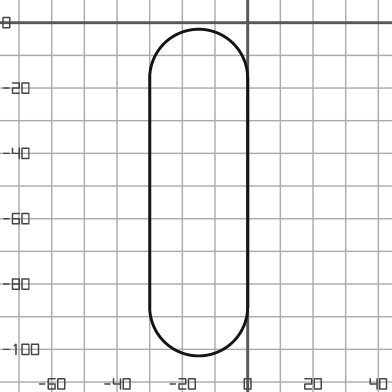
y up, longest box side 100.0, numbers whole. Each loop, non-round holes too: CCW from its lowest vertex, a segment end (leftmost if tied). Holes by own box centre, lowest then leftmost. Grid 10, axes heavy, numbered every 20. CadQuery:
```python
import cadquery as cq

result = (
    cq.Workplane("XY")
    .moveTo(-30.0, -87.0)
    .threePointArc((-15.0, -102.0), (0.0, -87.0))
    .lineTo(0.0, -17.0)
    .threePointArc((-15.0, -2.0), (-30.0, -17.0))
    .close()
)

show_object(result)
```